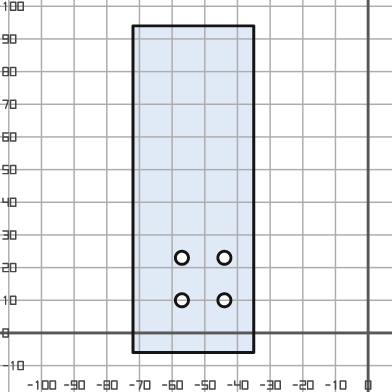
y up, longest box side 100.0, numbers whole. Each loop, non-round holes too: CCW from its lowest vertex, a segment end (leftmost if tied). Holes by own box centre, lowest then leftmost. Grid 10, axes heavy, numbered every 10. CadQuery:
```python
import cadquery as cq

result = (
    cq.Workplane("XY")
    .moveTo(-72.0, -6.0)
    .lineTo(-35.0, -6.0)
    .lineTo(-35.0, 94.0)
    .lineTo(-72.0, 94.0)
    .close()
    .moveTo(-57.0, 10.0)
    .circle(2.0)
    .moveTo(-44.0, 10.0)
    .circle(2.0)
    .moveTo(-57.0, 23.0)
    .circle(2.0)
    .moveTo(-44.0, 23.0)
    .circle(2.0)
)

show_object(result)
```